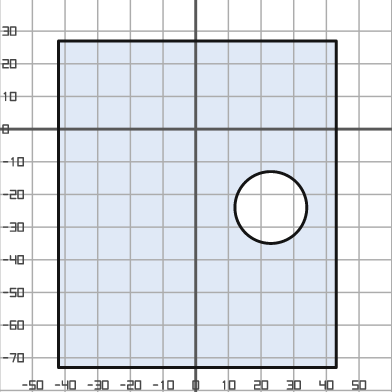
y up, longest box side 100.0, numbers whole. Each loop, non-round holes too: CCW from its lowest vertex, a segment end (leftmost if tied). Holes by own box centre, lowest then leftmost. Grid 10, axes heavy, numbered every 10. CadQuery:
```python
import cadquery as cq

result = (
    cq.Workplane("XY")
    .moveTo(-42.0, -73.0)
    .lineTo(43.0, -73.0)
    .lineTo(43.0, 27.0)
    .lineTo(-42.0, 27.0)
    .close()
    .moveTo(23.0, -24.0)
    .circle(11.0)
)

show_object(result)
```